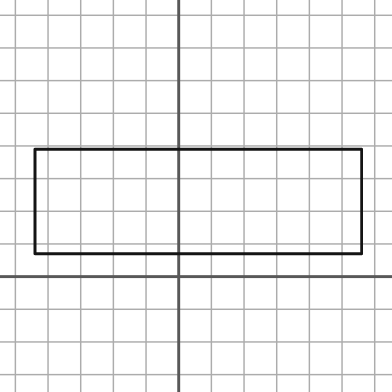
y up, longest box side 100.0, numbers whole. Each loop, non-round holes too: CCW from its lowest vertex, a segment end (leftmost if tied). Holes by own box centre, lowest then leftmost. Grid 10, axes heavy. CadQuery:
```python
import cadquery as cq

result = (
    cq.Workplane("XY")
    .moveTo(-44.0, 7.0)
    .lineTo(56.0, 7.0)
    .lineTo(56.0, 39.0)
    .lineTo(-44.0, 39.0)
    .close()
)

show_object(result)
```